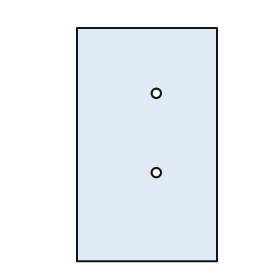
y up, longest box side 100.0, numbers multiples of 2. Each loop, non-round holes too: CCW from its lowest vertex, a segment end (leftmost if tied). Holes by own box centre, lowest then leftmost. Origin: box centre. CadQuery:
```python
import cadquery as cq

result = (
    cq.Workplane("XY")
    .moveTo(-30.0, -50.0)
    .lineTo(30.0, -50.0)
    .lineTo(30.0, 50.0)
    .lineTo(-30.0, 50.0)
    .close()
    .moveTo(4.0, -12.0)
    .circle(2.0)
    .moveTo(4.0, 22.0)
    .circle(2.0)
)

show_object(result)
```